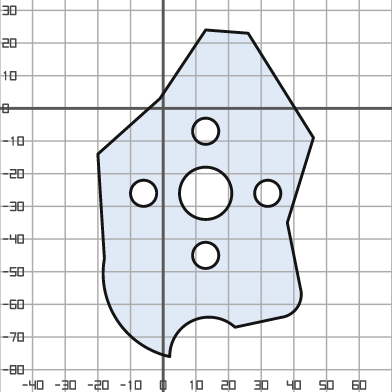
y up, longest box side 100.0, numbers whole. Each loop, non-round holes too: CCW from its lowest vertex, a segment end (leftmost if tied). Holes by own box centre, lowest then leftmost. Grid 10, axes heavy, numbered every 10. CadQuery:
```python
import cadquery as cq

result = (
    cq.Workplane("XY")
    .moveTo(2.0, -76.0)
    .threePointArc((9.0, -65.0), (22.0, -67.0))
    .lineTo(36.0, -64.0)
    .threePointArc((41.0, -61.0), (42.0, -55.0))
    .lineTo(38.0, -35.0)
    .lineTo(46.0, -9.0)
    .lineTo(26.0, 23.0)
    .lineTo(13.0, 24.0)
    .lineTo(-1.0, 3.0)
    .lineTo(-20.0, -14.0)
    .lineTo(-18.0, -46.0)
    .threePointArc((-14.0, -65.0), (2.0, -76.0))
    .close()
    .moveTo(13.0, -45.0)
    .circle(4.0)
    .moveTo(-6.0, -26.0)
    .circle(4.0)
    .moveTo(13.0, -26.0)
    .circle(8.0)
    .moveTo(32.0, -26.0)
    .circle(4.0)
    .moveTo(13.0, -7.0)
    .circle(4.0)
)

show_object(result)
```